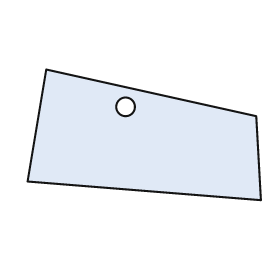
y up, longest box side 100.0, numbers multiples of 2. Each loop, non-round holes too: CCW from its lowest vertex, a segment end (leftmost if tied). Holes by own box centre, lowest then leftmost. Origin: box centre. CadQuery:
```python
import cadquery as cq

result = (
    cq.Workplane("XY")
    .moveTo(50.0, -28.0)
    .lineTo(48.0, 8.0)
    .lineTo(-42.0, 28.0)
    .lineTo(-50.0, -20.0)
    .close()
    .moveTo(-8.0, 12.0)
    .circle(4.0)
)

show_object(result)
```